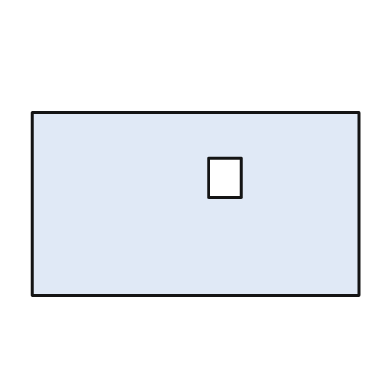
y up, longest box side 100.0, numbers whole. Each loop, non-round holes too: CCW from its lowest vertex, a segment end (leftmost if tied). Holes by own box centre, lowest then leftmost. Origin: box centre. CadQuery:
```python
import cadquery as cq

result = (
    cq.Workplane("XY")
    .moveTo(-50.0, -28.0)
    .lineTo(50.0, -28.0)
    .lineTo(50.0, 28.0)
    .lineTo(-50.0, 28.0)
    .close()
    .moveTo(4.0, 2.0)
    .lineTo(14.0, 2.0)
    .lineTo(14.0, 14.0)
    .lineTo(4.0, 14.0)
    .close()
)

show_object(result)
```